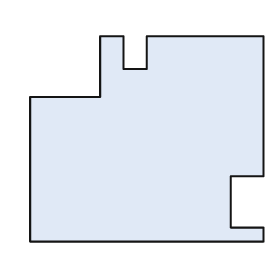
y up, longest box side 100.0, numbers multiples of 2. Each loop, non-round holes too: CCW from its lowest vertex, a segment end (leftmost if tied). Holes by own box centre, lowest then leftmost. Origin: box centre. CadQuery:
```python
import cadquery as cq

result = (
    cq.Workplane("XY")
    .moveTo(-50.0, -44.0)
    .lineTo(50.0, -44.0)
    .lineTo(50.0, -38.0)
    .lineTo(36.0, -38.0)
    .lineTo(36.0, -16.0)
    .lineTo(50.0, -16.0)
    .lineTo(50.0, 44.0)
    .lineTo(0.0, 44.0)
    .lineTo(0.0, 30.0)
    .lineTo(-10.0, 30.0)
    .lineTo(-10.0, 44.0)
    .lineTo(-20.0, 44.0)
    .lineTo(-20.0, 18.0)
    .lineTo(-50.0, 18.0)
    .close()
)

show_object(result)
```